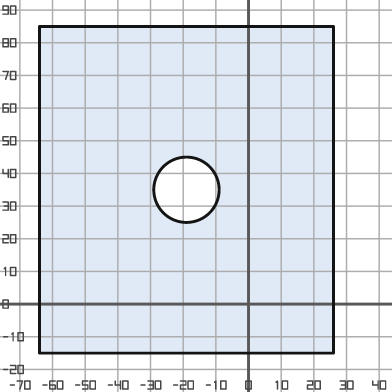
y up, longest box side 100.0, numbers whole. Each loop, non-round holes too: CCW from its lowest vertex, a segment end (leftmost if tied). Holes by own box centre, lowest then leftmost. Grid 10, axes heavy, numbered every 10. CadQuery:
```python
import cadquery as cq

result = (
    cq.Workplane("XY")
    .moveTo(-64.0, -15.0)
    .lineTo(26.0, -15.0)
    .lineTo(26.0, 85.0)
    .lineTo(-64.0, 85.0)
    .close()
    .moveTo(-19.0, 35.0)
    .circle(10.0)
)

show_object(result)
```